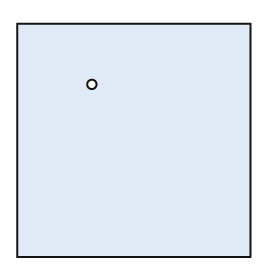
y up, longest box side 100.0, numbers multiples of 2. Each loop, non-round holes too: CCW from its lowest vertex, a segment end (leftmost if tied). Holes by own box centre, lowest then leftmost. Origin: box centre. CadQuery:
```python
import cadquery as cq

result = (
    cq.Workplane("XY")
    .moveTo(-50.0, -50.0)
    .lineTo(50.0, -50.0)
    .lineTo(50.0, 50.0)
    .lineTo(-50.0, 50.0)
    .close()
    .moveTo(-18.0, 24.0)
    .circle(2.0)
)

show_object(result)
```